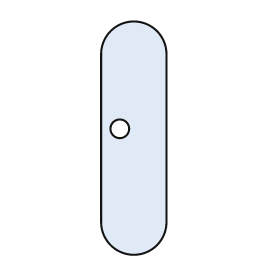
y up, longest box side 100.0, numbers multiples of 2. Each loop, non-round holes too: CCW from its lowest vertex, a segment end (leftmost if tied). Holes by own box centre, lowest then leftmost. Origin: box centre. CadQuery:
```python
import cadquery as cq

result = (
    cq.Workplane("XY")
    .moveTo(-14.0, -36.0)
    .threePointArc((0.0, -50.0), (14.0, -36.0))
    .lineTo(14.0, 36.0)
    .threePointArc((0.0, 50.0), (-14.0, 36.0))
    .close()
    .moveTo(-6.0, 4.0)
    .circle(4.0)
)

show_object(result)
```